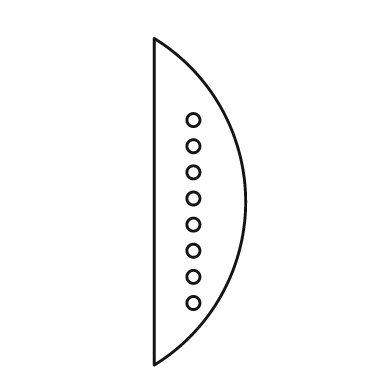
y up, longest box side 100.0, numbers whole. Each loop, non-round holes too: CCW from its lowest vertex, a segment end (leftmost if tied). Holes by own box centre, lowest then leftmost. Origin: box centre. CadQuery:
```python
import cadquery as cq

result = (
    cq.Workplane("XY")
    .moveTo(-14.0, -50.0)
    .threePointArc((14.0, 0.0), (-14.0, 50.0))
    .close()
    .moveTo(-2.0, -31.0)
    .circle(2.0)
    .moveTo(-2.0, -23.0)
    .circle(2.0)
    .moveTo(-2.0, -15.0)
    .circle(2.0)
    .moveTo(-2.0, -7.0)
    .circle(2.0)
    .moveTo(-2.0, 1.0)
    .circle(2.0)
    .moveTo(-2.0, 9.0)
    .circle(2.0)
    .moveTo(-2.0, 17.0)
    .circle(2.0)
    .moveTo(-2.0, 25.0)
    .circle(2.0)
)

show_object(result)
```